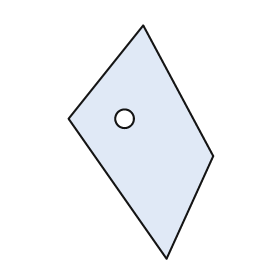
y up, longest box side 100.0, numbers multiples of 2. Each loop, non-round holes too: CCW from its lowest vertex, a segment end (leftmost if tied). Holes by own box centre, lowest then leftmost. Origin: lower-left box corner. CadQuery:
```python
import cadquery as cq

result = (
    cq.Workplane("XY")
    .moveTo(42.0, 0.0)
    .lineTo(62.0, 44.0)
    .lineTo(32.0, 100.0)
    .lineTo(0.0, 60.0)
    .close()
    .moveTo(24.0, 60.0)
    .circle(4.0)
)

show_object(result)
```